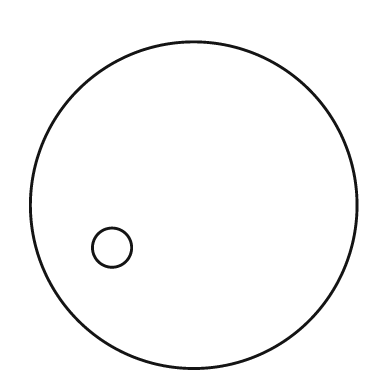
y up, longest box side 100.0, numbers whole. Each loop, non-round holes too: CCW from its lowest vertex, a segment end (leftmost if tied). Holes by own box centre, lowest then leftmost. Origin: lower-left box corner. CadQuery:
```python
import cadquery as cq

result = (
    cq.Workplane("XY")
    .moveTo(50.0, 50.0)
    .circle(50.0)
    .moveTo(25.0, 37.0)
    .circle(6.0)
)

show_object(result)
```